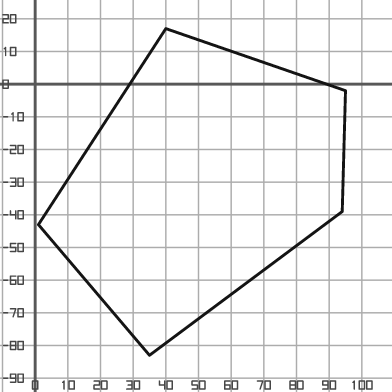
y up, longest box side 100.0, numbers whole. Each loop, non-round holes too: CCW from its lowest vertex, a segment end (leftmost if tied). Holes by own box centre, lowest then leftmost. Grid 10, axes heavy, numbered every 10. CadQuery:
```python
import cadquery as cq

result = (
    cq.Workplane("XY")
    .moveTo(35.0, -83.0)
    .lineTo(94.0, -39.0)
    .lineTo(95.0, -2.0)
    .lineTo(40.0, 17.0)
    .lineTo(1.0, -43.0)
    .close()
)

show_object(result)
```